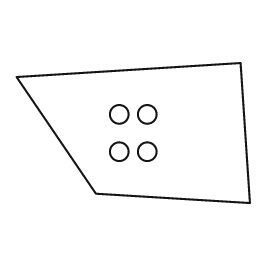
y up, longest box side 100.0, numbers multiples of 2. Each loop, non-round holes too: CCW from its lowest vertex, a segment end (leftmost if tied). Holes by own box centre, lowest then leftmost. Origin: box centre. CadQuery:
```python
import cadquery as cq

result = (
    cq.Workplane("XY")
    .moveTo(50.0, -30.0)
    .lineTo(46.0, 30.0)
    .lineTo(-50.0, 24.0)
    .lineTo(-16.0, -26.0)
    .close()
    .moveTo(-6.0, -8.0)
    .circle(4.0)
    .moveTo(6.0, -8.0)
    .circle(4.0)
    .moveTo(-6.0, 8.0)
    .circle(4.0)
    .moveTo(6.0, 8.0)
    .circle(4.0)
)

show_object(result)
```